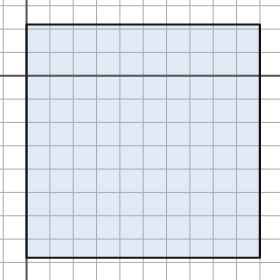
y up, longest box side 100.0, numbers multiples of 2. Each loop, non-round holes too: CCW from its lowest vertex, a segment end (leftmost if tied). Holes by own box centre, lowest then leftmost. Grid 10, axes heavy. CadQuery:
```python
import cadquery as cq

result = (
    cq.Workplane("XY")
    .moveTo(0.0, -78.0)
    .lineTo(100.0, -78.0)
    .lineTo(100.0, 22.0)
    .lineTo(0.0, 22.0)
    .close()
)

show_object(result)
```